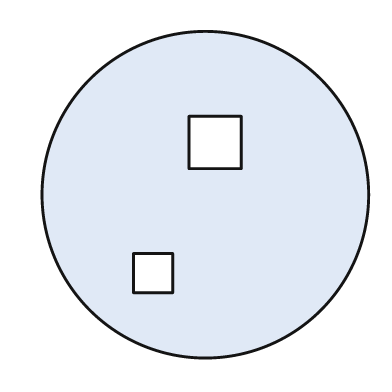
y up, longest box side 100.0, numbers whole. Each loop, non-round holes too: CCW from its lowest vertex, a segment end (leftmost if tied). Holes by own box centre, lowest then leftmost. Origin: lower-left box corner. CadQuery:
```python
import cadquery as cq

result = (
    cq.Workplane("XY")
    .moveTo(50.0, 50.0)
    .circle(50.0)
    .moveTo(28.0, 20.0)
    .lineTo(40.0, 20.0)
    .lineTo(40.0, 32.0)
    .lineTo(28.0, 32.0)
    .close()
    .moveTo(45.0, 58.0)
    .lineTo(61.0, 58.0)
    .lineTo(61.0, 74.0)
    .lineTo(45.0, 74.0)
    .close()
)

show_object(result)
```